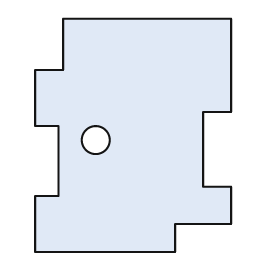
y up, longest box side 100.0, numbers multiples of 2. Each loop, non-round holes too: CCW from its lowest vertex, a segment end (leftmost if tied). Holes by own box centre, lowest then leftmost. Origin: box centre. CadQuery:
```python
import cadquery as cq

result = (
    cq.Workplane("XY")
    .moveTo(-42.0, -50.0)
    .lineTo(18.0, -50.0)
    .lineTo(18.0, -38.0)
    .lineTo(42.0, -38.0)
    .lineTo(42.0, -22.0)
    .lineTo(30.0, -22.0)
    .lineTo(30.0, 10.0)
    .lineTo(42.0, 10.0)
    .lineTo(42.0, 50.0)
    .lineTo(-30.0, 50.0)
    .lineTo(-30.0, 28.0)
    .lineTo(-42.0, 28.0)
    .lineTo(-42.0, 4.0)
    .lineTo(-32.0, 4.0)
    .lineTo(-32.0, -26.0)
    .lineTo(-42.0, -26.0)
    .close()
    .moveTo(-16.0, -2.0)
    .circle(6.0)
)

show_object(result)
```